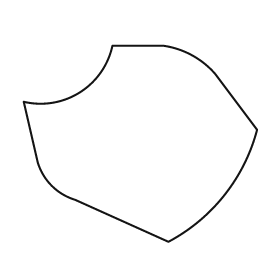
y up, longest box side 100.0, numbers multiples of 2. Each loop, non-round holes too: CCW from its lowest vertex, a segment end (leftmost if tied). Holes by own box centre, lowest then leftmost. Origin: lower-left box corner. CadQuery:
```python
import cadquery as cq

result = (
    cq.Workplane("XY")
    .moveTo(62.0, 0.0)
    .threePointArc((86.0, 20.0), (100.0, 48.0))
    .lineTo(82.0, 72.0)
    .threePointArc((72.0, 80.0), (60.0, 84.0))
    .lineTo(38.0, 84.0)
    .threePointArc((24.0, 64.0), (0.0, 60.0))
    .lineTo(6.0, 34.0)
    .threePointArc((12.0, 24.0), (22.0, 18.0))
    .close()
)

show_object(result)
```